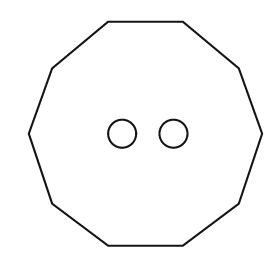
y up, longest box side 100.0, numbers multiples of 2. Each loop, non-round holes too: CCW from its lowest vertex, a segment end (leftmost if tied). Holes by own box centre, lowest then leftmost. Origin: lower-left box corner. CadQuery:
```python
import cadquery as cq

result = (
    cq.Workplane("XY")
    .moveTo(34.0, 0.0)
    .lineTo(66.0, 0.0)
    .lineTo(90.0, 18.0)
    .lineTo(100.0, 48.0)
    .lineTo(90.0, 76.0)
    .lineTo(66.0, 96.0)
    .lineTo(34.0, 96.0)
    .lineTo(10.0, 76.0)
    .lineTo(0.0, 48.0)
    .lineTo(10.0, 18.0)
    .close()
    .moveTo(40.0, 48.0)
    .circle(6.0)
    .moveTo(62.0, 48.0)
    .circle(6.0)
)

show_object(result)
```